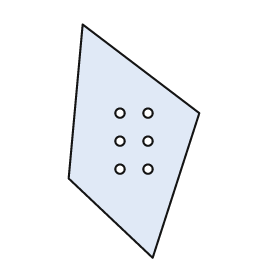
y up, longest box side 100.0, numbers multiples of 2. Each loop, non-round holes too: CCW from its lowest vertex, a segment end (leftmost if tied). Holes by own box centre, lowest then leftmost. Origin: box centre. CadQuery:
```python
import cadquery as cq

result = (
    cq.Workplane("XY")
    .moveTo(8.0, -50.0)
    .lineTo(28.0, 12.0)
    .lineTo(-22.0, 50.0)
    .lineTo(-28.0, -16.0)
    .close()
    .moveTo(-6.0, -12.0)
    .circle(2.0)
    .moveTo(6.0, -12.0)
    .circle(2.0)
    .moveTo(-6.0, 0.0)
    .circle(2.0)
    .moveTo(6.0, 0.0)
    .circle(2.0)
    .moveTo(-6.0, 12.0)
    .circle(2.0)
    .moveTo(6.0, 12.0)
    .circle(2.0)
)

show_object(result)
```